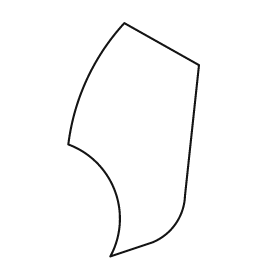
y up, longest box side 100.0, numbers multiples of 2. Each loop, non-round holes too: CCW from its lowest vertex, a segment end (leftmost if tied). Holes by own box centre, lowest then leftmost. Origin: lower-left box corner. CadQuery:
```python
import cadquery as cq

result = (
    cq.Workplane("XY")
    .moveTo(18.0, 0.0)
    .lineTo(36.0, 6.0)
    .threePointArc((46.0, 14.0), (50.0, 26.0))
    .lineTo(56.0, 82.0)
    .lineTo(24.0, 100.0)
    .threePointArc((8.0, 76.0), (0.0, 48.0))
    .threePointArc((20.0, 28.0), (18.0, 0.0))
    .close()
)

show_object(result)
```